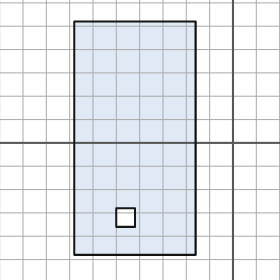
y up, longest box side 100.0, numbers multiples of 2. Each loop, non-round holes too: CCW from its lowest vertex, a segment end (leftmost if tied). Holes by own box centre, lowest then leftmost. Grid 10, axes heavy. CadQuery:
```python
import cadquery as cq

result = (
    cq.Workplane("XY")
    .moveTo(-68.0, -48.0)
    .lineTo(-16.0, -48.0)
    .lineTo(-16.0, 52.0)
    .lineTo(-68.0, 52.0)
    .close()
    .moveTo(-50.0, -36.0)
    .lineTo(-42.0, -36.0)
    .lineTo(-42.0, -28.0)
    .lineTo(-50.0, -28.0)
    .close()
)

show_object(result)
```